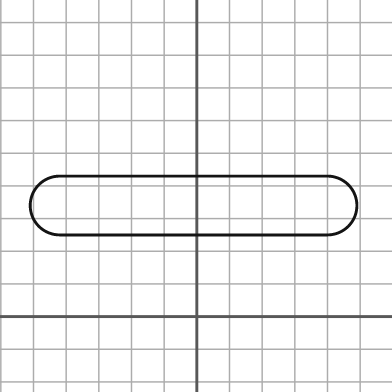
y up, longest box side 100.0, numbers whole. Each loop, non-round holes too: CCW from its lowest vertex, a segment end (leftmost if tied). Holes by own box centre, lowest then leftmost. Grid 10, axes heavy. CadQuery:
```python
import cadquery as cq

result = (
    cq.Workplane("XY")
    .moveTo(-42.0, 25.0)
    .lineTo(40.0, 25.0)
    .threePointArc((49.0, 34.0), (40.0, 43.0))
    .lineTo(-42.0, 43.0)
    .threePointArc((-51.0, 34.0), (-42.0, 25.0))
    .close()
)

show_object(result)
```